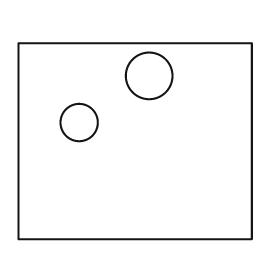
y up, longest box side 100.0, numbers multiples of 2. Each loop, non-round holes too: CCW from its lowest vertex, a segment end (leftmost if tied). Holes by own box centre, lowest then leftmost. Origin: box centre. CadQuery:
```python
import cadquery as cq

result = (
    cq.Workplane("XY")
    .moveTo(-50.0, -42.0)
    .lineTo(50.0, -42.0)
    .lineTo(50.0, 42.0)
    .lineTo(-50.0, 42.0)
    .close()
    .moveTo(-24.0, 8.0)
    .circle(8.0)
    .moveTo(6.0, 28.0)
    .circle(10.0)
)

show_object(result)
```